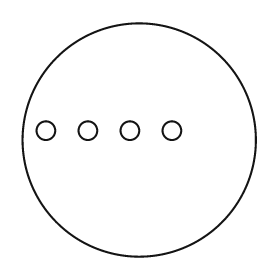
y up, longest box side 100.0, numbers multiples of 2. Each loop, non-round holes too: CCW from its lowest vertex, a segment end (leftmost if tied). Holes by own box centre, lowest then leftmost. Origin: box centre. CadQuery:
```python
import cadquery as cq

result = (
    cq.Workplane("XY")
    .moveTo(0.0, 0.0)
    .circle(50.0)
    .moveTo(-40.0, 4.0)
    .circle(4.0)
    .moveTo(-22.0, 4.0)
    .circle(4.0)
    .moveTo(-4.0, 4.0)
    .circle(4.0)
    .moveTo(14.0, 4.0)
    .circle(4.0)
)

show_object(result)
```